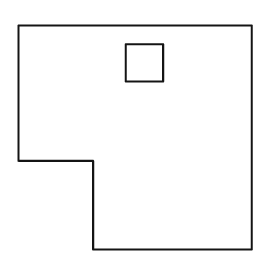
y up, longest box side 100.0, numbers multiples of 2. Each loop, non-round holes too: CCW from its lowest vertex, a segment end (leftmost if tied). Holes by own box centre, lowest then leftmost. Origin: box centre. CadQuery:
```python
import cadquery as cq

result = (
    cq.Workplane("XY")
    .moveTo(-18.0, -48.0)
    .lineTo(50.0, -48.0)
    .lineTo(50.0, 48.0)
    .lineTo(-50.0, 48.0)
    .lineTo(-50.0, -10.0)
    .lineTo(-18.0, -10.0)
    .close()
    .moveTo(-4.0, 24.0)
    .lineTo(12.0, 24.0)
    .lineTo(12.0, 40.0)
    .lineTo(-4.0, 40.0)
    .close()
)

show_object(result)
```